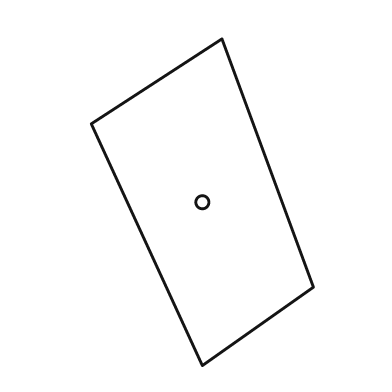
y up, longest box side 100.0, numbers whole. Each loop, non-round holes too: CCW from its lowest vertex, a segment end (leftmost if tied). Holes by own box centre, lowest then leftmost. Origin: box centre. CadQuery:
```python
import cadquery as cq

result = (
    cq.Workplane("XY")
    .moveTo(0.0, -50.0)
    .lineTo(34.0, -26.0)
    .lineTo(6.0, 50.0)
    .lineTo(-34.0, 24.0)
    .close()
    .moveTo(0.0, 0.0)
    .circle(2.0)
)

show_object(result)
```